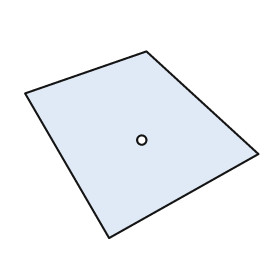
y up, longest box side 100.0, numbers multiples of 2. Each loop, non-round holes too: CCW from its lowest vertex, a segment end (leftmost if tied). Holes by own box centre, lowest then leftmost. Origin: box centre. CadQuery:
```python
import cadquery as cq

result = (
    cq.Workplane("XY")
    .moveTo(-14.0, -40.0)
    .lineTo(50.0, -4.0)
    .lineTo(2.0, 40.0)
    .lineTo(-50.0, 22.0)
    .close()
    .moveTo(0.0, 2.0)
    .circle(2.0)
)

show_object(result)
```